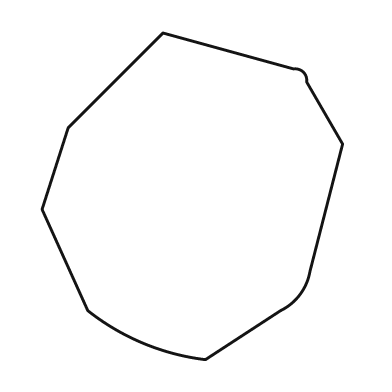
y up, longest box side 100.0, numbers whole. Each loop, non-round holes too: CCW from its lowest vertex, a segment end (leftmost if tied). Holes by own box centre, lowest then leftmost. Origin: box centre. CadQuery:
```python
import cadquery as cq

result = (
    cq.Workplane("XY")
    .moveTo(4.0, -50.0)
    .lineTo(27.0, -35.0)
    .threePointArc((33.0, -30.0), (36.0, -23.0))
    .lineTo(46.0, 16.0)
    .lineTo(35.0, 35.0)
    .threePointArc((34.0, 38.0), (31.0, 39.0))
    .lineTo(-9.0, 50.0)
    .lineTo(-38.0, 21.0)
    .lineTo(-46.0, -4.0)
    .lineTo(-32.0, -35.0)
    .threePointArc((-15.0, -45.0), (4.0, -50.0))
    .close()
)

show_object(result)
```